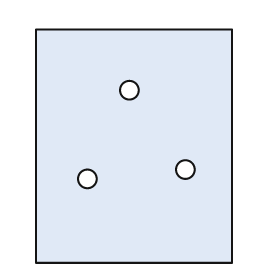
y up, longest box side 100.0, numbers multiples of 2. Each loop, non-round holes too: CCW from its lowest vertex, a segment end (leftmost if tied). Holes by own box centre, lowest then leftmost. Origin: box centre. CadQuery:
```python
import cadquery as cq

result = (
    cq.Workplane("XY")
    .moveTo(-42.0, -50.0)
    .lineTo(42.0, -50.0)
    .lineTo(42.0, 50.0)
    .lineTo(-42.0, 50.0)
    .close()
    .moveTo(-20.0, -14.0)
    .circle(4.0)
    .moveTo(22.0, -10.0)
    .circle(4.0)
    .moveTo(-2.0, 24.0)
    .circle(4.0)
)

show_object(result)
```